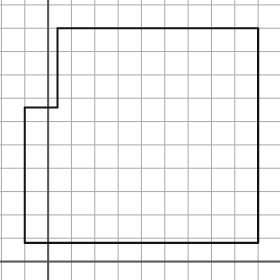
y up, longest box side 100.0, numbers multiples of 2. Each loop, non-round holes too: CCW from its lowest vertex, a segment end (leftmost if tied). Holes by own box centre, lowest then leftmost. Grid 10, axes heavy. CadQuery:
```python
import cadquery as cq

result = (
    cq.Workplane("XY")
    .moveTo(-10.0, 8.0)
    .lineTo(90.0, 8.0)
    .lineTo(90.0, 100.0)
    .lineTo(4.0, 100.0)
    .lineTo(4.0, 66.0)
    .lineTo(-10.0, 66.0)
    .close()
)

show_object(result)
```